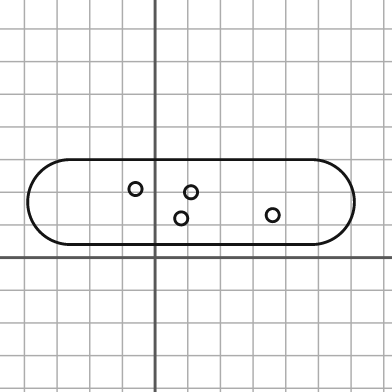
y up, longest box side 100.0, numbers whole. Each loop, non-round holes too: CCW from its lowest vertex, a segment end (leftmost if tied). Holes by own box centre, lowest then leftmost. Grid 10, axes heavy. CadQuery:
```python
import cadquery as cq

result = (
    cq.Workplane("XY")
    .moveTo(-26.0, 4.0)
    .lineTo(48.0, 4.0)
    .threePointArc((61.0, 17.0), (48.0, 30.0))
    .lineTo(-26.0, 30.0)
    .threePointArc((-39.0, 17.0), (-26.0, 4.0))
    .close()
    .moveTo(8.0, 12.0)
    .circle(2.0)
    .moveTo(36.0, 13.0)
    .circle(2.0)
    .moveTo(11.0, 20.0)
    .circle(2.0)
    .moveTo(-6.0, 21.0)
    .circle(2.0)
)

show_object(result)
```